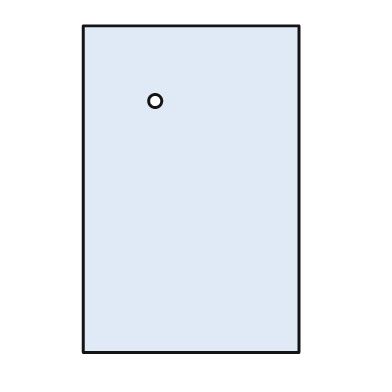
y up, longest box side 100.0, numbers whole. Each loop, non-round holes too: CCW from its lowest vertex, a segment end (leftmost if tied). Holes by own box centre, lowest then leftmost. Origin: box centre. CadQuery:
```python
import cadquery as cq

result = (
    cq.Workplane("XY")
    .moveTo(-33.0, -50.0)
    .lineTo(33.0, -50.0)
    .lineTo(33.0, 50.0)
    .lineTo(-33.0, 50.0)
    .close()
    .moveTo(-11.0, 27.0)
    .circle(2.0)
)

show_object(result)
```